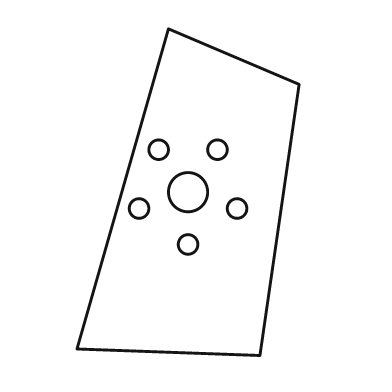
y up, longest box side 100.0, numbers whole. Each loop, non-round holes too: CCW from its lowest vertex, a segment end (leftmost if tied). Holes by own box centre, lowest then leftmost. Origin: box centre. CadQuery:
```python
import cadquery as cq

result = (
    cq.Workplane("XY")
    .moveTo(22.0, -50.0)
    .lineTo(34.0, 33.0)
    .lineTo(-6.0, 50.0)
    .lineTo(-34.0, -48.0)
    .close()
    .moveTo(0.0, -16.0)
    .circle(3.0)
    .moveTo(-15.0, -5.0)
    .circle(3.0)
    .moveTo(15.0, -5.0)
    .circle(3.0)
    .moveTo(0.0, 0.0)
    .circle(6.0)
    .moveTo(-9.0, 13.0)
    .circle(3.0)
    .moveTo(9.0, 13.0)
    .circle(3.0)
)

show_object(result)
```